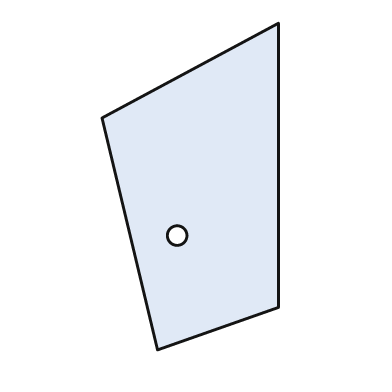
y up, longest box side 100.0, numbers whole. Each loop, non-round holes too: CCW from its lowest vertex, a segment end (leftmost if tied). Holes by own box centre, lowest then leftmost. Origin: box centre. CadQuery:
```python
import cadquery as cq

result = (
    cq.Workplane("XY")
    .moveTo(-10.0, -50.0)
    .lineTo(27.0, -37.0)
    .lineTo(27.0, 50.0)
    .lineTo(-27.0, 21.0)
    .close()
    .moveTo(-4.0, -15.0)
    .circle(3.0)
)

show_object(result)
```